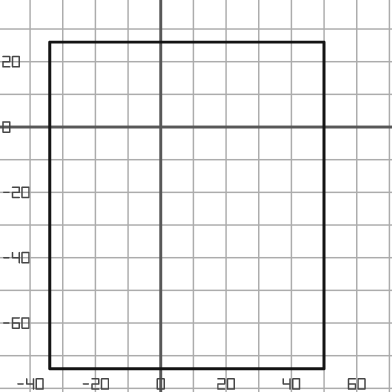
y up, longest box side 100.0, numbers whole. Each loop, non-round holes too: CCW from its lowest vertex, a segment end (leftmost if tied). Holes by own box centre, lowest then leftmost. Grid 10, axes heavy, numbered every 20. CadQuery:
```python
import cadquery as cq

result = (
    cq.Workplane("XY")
    .moveTo(-34.0, -74.0)
    .lineTo(50.0, -74.0)
    .lineTo(50.0, 26.0)
    .lineTo(-34.0, 26.0)
    .close()
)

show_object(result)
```